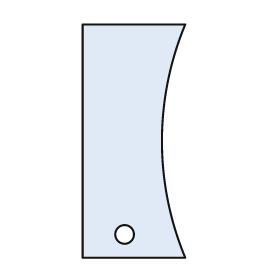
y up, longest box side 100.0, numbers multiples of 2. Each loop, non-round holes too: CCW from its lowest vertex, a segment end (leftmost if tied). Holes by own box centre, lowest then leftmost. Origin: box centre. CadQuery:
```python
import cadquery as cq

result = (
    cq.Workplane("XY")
    .moveTo(-22.0, -50.0)
    .lineTo(22.0, -50.0)
    .threePointArc((12.0, 0.0), (22.0, 50.0))
    .lineTo(-22.0, 50.0)
    .close()
    .moveTo(-4.0, -40.0)
    .circle(4.0)
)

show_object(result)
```